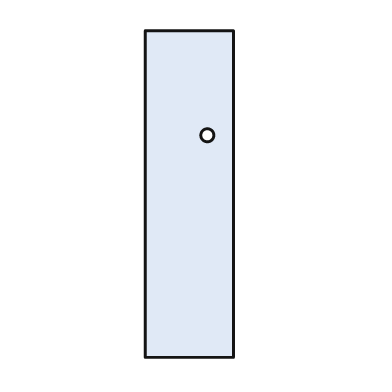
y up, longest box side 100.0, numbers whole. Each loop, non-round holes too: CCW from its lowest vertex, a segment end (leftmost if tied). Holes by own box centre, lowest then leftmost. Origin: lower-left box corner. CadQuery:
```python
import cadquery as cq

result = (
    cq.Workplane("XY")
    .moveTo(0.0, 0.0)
    .lineTo(27.0, 0.0)
    .lineTo(27.0, 100.0)
    .lineTo(0.0, 100.0)
    .close()
    .moveTo(19.0, 68.0)
    .circle(2.0)
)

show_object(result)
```